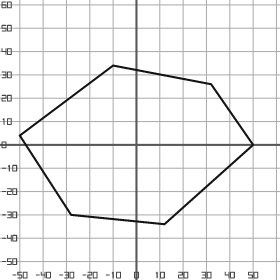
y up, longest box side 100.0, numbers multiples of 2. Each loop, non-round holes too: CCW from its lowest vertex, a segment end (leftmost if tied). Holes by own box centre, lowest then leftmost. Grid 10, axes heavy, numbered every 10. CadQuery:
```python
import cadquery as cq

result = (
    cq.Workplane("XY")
    .moveTo(12.0, -34.0)
    .lineTo(50.0, 0.0)
    .lineTo(32.0, 26.0)
    .lineTo(-10.0, 34.0)
    .lineTo(-50.0, 4.0)
    .lineTo(-28.0, -30.0)
    .close()
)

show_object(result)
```